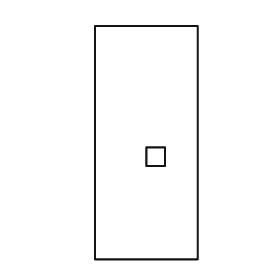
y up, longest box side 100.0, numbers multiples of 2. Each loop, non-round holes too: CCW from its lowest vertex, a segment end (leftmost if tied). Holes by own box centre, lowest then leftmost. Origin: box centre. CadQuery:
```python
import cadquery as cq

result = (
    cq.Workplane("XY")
    .moveTo(-22.0, -50.0)
    .lineTo(22.0, -50.0)
    .lineTo(22.0, 50.0)
    .lineTo(-22.0, 50.0)
    .close()
    .moveTo(0.0, -10.0)
    .lineTo(8.0, -10.0)
    .lineTo(8.0, -2.0)
    .lineTo(0.0, -2.0)
    .close()
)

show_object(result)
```